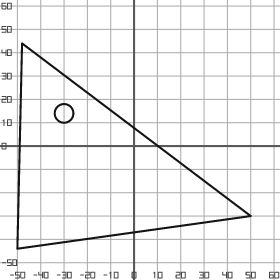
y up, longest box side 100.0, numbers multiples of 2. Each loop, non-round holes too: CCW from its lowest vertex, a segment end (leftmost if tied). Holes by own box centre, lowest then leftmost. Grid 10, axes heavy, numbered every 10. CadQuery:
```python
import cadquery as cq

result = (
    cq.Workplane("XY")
    .moveTo(-50.0, -44.0)
    .lineTo(50.0, -30.0)
    .lineTo(-48.0, 44.0)
    .close()
    .moveTo(-30.0, 14.0)
    .circle(4.0)
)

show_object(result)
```